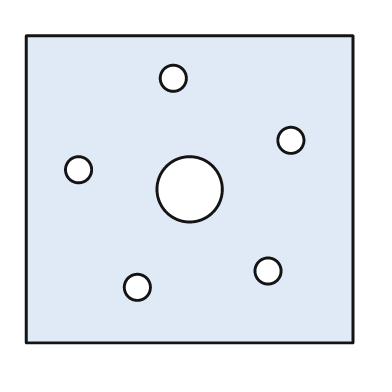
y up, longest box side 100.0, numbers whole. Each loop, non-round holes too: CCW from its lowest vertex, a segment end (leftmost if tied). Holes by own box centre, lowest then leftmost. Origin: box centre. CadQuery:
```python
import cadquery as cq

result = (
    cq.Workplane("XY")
    .moveTo(-50.0, -47.0)
    .lineTo(50.0, -47.0)
    .lineTo(50.0, 47.0)
    .lineTo(-50.0, 47.0)
    .close()
    .moveTo(-16.0, -30.0)
    .circle(4.0)
    .moveTo(24.0, -25.0)
    .circle(4.0)
    .moveTo(0.0, 0.0)
    .circle(10.0)
    .moveTo(-34.0, 6.0)
    .circle(4.0)
    .moveTo(31.0, 15.0)
    .circle(4.0)
    .moveTo(-5.0, 34.0)
    .circle(4.0)
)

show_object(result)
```